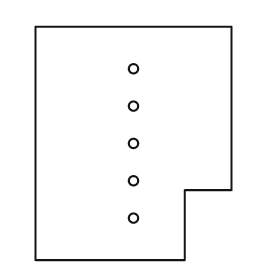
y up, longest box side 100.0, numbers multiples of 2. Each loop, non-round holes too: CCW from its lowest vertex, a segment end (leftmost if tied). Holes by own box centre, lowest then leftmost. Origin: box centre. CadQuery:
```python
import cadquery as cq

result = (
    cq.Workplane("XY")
    .moveTo(-42.0, -50.0)
    .lineTo(22.0, -50.0)
    .lineTo(22.0, -20.0)
    .lineTo(42.0, -20.0)
    .lineTo(42.0, 50.0)
    .lineTo(-42.0, 50.0)
    .close()
    .moveTo(0.0, -32.0)
    .circle(2.0)
    .moveTo(0.0, -16.0)
    .circle(2.0)
    .moveTo(0.0, 0.0)
    .circle(2.0)
    .moveTo(0.0, 16.0)
    .circle(2.0)
    .moveTo(0.0, 32.0)
    .circle(2.0)
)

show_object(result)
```